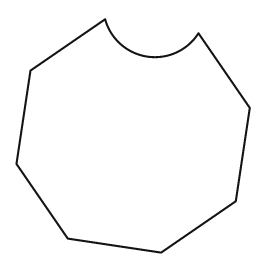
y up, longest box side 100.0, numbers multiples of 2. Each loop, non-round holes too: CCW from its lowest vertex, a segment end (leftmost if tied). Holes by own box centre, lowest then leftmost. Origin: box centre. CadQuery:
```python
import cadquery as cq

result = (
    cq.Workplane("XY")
    .moveTo(12.0, -50.0)
    .lineTo(44.0, -28.0)
    .lineTo(50.0, 12.0)
    .lineTo(28.0, 44.0)
    .threePointArc((6.0, 34.0), (-12.0, 50.0))
    .lineTo(-44.0, 28.0)
    .lineTo(-50.0, -12.0)
    .lineTo(-28.0, -44.0)
    .close()
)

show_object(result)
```